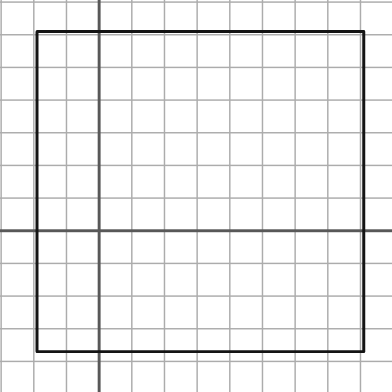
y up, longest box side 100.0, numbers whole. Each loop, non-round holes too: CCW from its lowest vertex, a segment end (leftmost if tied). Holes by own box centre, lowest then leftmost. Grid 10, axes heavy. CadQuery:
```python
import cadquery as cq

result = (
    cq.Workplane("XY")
    .moveTo(-19.0, -37.0)
    .lineTo(81.0, -37.0)
    .lineTo(81.0, 61.0)
    .lineTo(-19.0, 61.0)
    .close()
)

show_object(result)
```